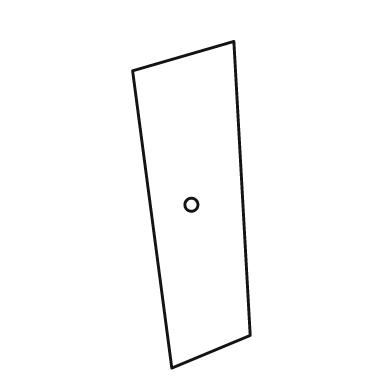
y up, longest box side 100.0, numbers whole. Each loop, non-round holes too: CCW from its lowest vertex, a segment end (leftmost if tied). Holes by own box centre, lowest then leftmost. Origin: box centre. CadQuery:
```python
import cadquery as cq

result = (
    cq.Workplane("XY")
    .moveTo(-6.0, -50.0)
    .lineTo(18.0, -40.0)
    .lineTo(13.0, 50.0)
    .lineTo(-18.0, 41.0)
    .close()
    .moveTo(0.0, 0.0)
    .circle(2.0)
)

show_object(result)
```